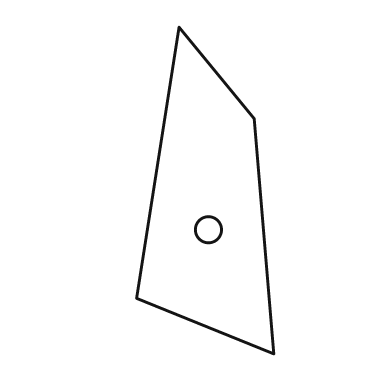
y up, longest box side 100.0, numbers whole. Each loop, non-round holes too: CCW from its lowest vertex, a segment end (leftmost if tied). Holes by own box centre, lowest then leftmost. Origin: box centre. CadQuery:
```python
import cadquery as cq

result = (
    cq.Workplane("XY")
    .moveTo(21.0, -50.0)
    .lineTo(15.0, 22.0)
    .lineTo(-8.0, 50.0)
    .lineTo(-21.0, -33.0)
    .close()
    .moveTo(1.0, -12.0)
    .circle(4.0)
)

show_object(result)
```